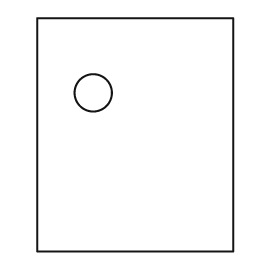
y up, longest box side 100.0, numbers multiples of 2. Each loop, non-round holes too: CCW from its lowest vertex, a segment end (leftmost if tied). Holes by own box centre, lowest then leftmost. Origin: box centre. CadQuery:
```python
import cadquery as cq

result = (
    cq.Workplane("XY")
    .moveTo(-42.0, -50.0)
    .lineTo(42.0, -50.0)
    .lineTo(42.0, 50.0)
    .lineTo(-42.0, 50.0)
    .close()
    .moveTo(-18.0, 18.0)
    .circle(8.0)
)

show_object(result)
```